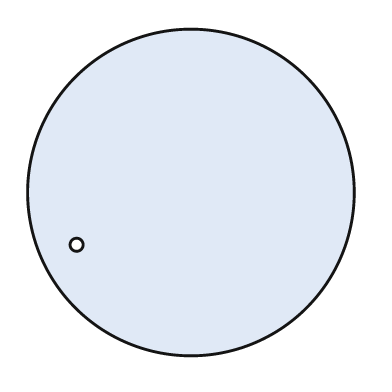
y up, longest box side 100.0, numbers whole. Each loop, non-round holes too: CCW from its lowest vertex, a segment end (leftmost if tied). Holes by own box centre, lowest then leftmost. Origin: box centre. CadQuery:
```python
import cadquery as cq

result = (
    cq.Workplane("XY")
    .moveTo(0.0, 0.0)
    .circle(50.0)
    .moveTo(-35.0, -16.0)
    .circle(2.0)
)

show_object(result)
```